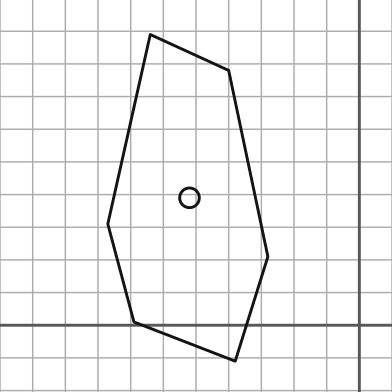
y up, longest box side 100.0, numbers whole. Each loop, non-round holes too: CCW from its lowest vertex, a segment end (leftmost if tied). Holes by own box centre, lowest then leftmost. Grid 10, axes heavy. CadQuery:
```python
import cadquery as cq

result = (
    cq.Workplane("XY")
    .moveTo(-38.0, -11.0)
    .lineTo(-28.0, 21.0)
    .lineTo(-40.0, 78.0)
    .lineTo(-64.0, 89.0)
    .lineTo(-77.0, 31.0)
    .lineTo(-69.0, 1.0)
    .close()
    .moveTo(-52.0, 39.0)
    .circle(3.0)
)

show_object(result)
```